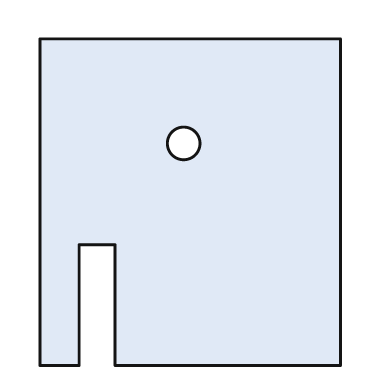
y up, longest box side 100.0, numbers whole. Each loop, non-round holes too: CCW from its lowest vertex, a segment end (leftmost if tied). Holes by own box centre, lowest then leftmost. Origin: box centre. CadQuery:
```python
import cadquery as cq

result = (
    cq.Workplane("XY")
    .moveTo(-46.0, -50.0)
    .lineTo(-34.0, -50.0)
    .lineTo(-34.0, -13.0)
    .lineTo(-23.0, -13.0)
    .lineTo(-23.0, -50.0)
    .lineTo(46.0, -50.0)
    .lineTo(46.0, 50.0)
    .lineTo(-46.0, 50.0)
    .close()
    .moveTo(-2.0, 18.0)
    .circle(5.0)
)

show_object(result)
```